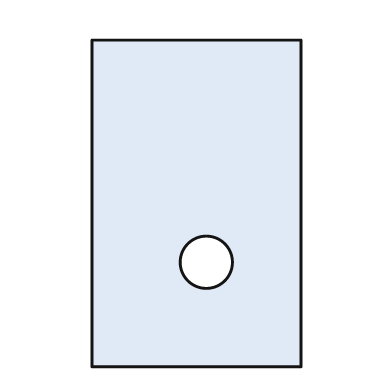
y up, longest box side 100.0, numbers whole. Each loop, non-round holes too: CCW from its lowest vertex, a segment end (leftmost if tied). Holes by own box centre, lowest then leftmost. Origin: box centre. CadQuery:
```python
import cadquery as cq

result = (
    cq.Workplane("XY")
    .moveTo(-32.0, -50.0)
    .lineTo(32.0, -50.0)
    .lineTo(32.0, 50.0)
    .lineTo(-32.0, 50.0)
    .close()
    .moveTo(3.0, -18.0)
    .circle(8.0)
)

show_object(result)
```